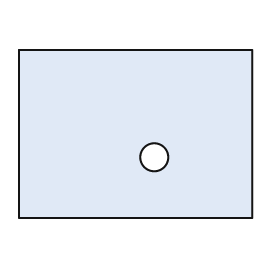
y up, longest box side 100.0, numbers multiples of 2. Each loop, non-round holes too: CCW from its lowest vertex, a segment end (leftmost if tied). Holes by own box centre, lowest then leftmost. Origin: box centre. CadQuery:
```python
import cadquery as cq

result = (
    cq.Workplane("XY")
    .moveTo(-50.0, -36.0)
    .lineTo(50.0, -36.0)
    .lineTo(50.0, 36.0)
    .lineTo(-50.0, 36.0)
    .close()
    .moveTo(8.0, -10.0)
    .circle(6.0)
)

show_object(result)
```